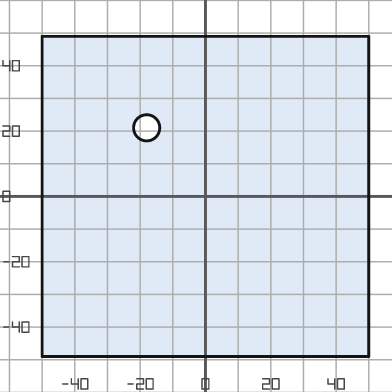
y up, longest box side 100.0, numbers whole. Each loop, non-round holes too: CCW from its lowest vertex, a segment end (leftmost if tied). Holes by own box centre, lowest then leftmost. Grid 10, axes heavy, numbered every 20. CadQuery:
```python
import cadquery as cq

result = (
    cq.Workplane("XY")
    .moveTo(-50.0, -49.0)
    .lineTo(50.0, -49.0)
    .lineTo(50.0, 49.0)
    .lineTo(-50.0, 49.0)
    .close()
    .moveTo(-18.0, 21.0)
    .circle(4.0)
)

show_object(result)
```